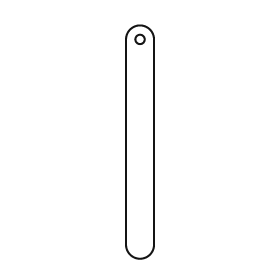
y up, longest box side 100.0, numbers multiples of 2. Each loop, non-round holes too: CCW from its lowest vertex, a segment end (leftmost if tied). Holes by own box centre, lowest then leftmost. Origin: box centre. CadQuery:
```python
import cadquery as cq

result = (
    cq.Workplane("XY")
    .moveTo(-6.0, -44.0)
    .threePointArc((0.0, -50.0), (6.0, -44.0))
    .lineTo(6.0, 44.0)
    .threePointArc((0.0, 50.0), (-6.0, 44.0))
    .close()
    .moveTo(0.0, 44.0)
    .circle(2.0)
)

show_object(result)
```